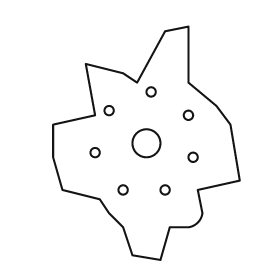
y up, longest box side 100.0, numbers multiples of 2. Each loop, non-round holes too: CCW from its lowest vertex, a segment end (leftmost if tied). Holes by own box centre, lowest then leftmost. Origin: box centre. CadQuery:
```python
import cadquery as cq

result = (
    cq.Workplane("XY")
    .moveTo(6.0, -50.0)
    .lineTo(10.0, -36.0)
    .lineTo(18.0, -36.0)
    .threePointArc((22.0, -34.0), (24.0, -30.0))
    .lineTo(22.0, -20.0)
    .lineTo(40.0, -16.0)
    .lineTo(36.0, 8.0)
    .lineTo(30.0, 16.0)
    .lineTo(18.0, 26.0)
    .lineTo(18.0, 50.0)
    .lineTo(8.0, 48.0)
    .lineTo(-4.0, 26.0)
    .lineTo(-10.0, 30.0)
    .lineTo(-26.0, 34.0)
    .lineTo(-22.0, 12.0)
    .lineTo(-40.0, 8.0)
    .lineTo(-40.0, -6.0)
    .lineTo(-36.0, -20.0)
    .lineTo(-20.0, -24.0)
    .lineTo(-16.0, -30.0)
    .lineTo(-10.0, -36.0)
    .lineTo(-6.0, -48.0)
    .close()
    .moveTo(-10.0, -20.0)
    .circle(2.0)
    .moveTo(8.0, -20.0)
    .circle(2.0)
    .moveTo(20.0, -6.0)
    .circle(2.0)
    .moveTo(-22.0, -4.0)
    .circle(2.0)
    .moveTo(0.0, 0.0)
    .circle(6.0)
    .moveTo(18.0, 12.0)
    .circle(2.0)
    .moveTo(-16.0, 14.0)
    .circle(2.0)
    .moveTo(2.0, 22.0)
    .circle(2.0)
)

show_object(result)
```